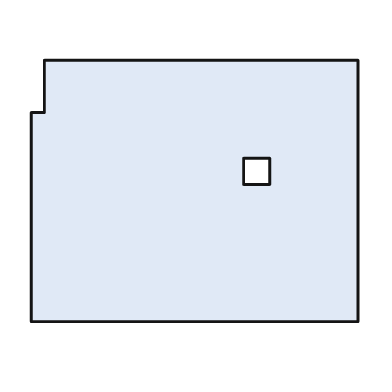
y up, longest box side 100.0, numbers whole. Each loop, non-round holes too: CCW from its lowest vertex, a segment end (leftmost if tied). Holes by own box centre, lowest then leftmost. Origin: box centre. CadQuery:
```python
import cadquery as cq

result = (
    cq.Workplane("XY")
    .moveTo(-50.0, -40.0)
    .lineTo(50.0, -40.0)
    .lineTo(50.0, 40.0)
    .lineTo(-46.0, 40.0)
    .lineTo(-46.0, 24.0)
    .lineTo(-50.0, 24.0)
    .close()
    .moveTo(15.0, 2.0)
    .lineTo(23.0, 2.0)
    .lineTo(23.0, 10.0)
    .lineTo(15.0, 10.0)
    .close()
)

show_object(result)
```